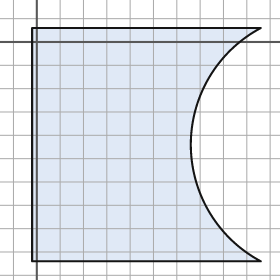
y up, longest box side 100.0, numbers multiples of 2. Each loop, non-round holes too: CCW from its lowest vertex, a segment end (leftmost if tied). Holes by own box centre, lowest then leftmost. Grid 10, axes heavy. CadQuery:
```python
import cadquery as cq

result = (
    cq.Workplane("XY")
    .moveTo(-2.0, -94.0)
    .lineTo(96.0, -94.0)
    .threePointArc((66.0, -44.0), (96.0, 6.0))
    .lineTo(-2.0, 6.0)
    .close()
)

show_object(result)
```